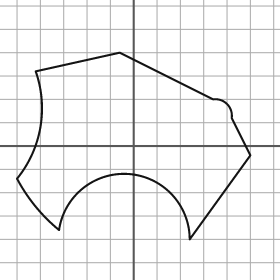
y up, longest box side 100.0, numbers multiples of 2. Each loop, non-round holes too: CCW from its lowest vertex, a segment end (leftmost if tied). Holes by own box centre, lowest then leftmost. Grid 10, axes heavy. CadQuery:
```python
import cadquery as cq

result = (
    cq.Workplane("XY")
    .moveTo(24.0, -40.0)
    .lineTo(50.0, -4.0)
    .lineTo(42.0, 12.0)
    .threePointArc((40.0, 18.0), (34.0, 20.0))
    .lineTo(-6.0, 40.0)
    .lineTo(-42.0, 32.0)
    .threePointArc((-40.0, 8.0), (-50.0, -14.0))
    .threePointArc((-42.0, -26.0), (-32.0, -36.0))
    .threePointArc((-2.0, -12.0), (24.0, -40.0))
    .close()
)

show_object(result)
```